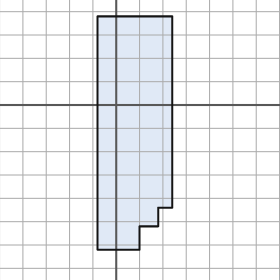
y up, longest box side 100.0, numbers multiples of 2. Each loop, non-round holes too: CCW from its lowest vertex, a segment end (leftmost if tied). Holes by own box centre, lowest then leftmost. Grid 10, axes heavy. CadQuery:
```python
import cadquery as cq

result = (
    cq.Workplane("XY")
    .moveTo(-8.0, -62.0)
    .lineTo(10.0, -62.0)
    .lineTo(10.0, -52.0)
    .lineTo(18.0, -52.0)
    .lineTo(18.0, -44.0)
    .lineTo(24.0, -44.0)
    .lineTo(24.0, 38.0)
    .lineTo(-8.0, 38.0)
    .close()
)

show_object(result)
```